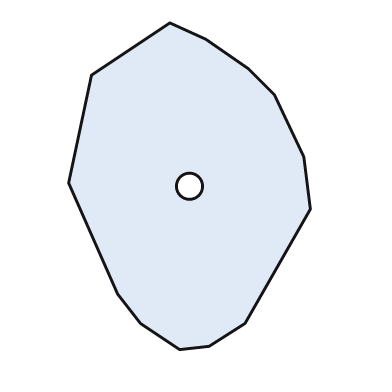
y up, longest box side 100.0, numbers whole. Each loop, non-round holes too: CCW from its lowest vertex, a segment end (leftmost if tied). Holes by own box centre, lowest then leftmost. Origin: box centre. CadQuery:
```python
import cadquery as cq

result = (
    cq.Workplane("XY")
    .moveTo(-3.0, -50.0)
    .lineTo(6.0, -49.0)
    .lineTo(17.0, -42.0)
    .lineTo(37.0, -7.0)
    .lineTo(35.0, 9.0)
    .lineTo(26.0, 28.0)
    .lineTo(18.0, 36.0)
    .lineTo(5.0, 45.0)
    .lineTo(-6.0, 50.0)
    .lineTo(-30.0, 34.0)
    .lineTo(-37.0, 1.0)
    .lineTo(-22.0, -33.0)
    .lineTo(-15.0, -42.0)
    .close()
    .moveTo(0.0, 0.0)
    .circle(4.0)
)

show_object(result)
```